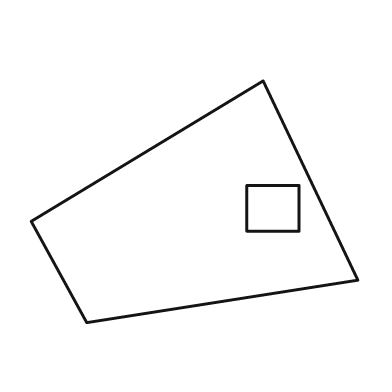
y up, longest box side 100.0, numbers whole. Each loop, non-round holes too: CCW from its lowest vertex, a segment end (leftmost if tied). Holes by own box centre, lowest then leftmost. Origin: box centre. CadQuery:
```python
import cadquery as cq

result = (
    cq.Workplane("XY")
    .moveTo(-33.0, -37.0)
    .lineTo(50.0, -24.0)
    .lineTo(21.0, 37.0)
    .lineTo(-50.0, -6.0)
    .close()
    .moveTo(16.0, -9.0)
    .lineTo(32.0, -9.0)
    .lineTo(32.0, 5.0)
    .lineTo(16.0, 5.0)
    .close()
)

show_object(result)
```